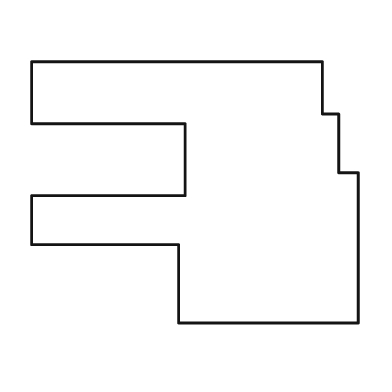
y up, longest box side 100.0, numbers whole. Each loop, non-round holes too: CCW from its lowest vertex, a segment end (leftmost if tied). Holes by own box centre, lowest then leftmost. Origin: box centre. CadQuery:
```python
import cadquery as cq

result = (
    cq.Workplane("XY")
    .moveTo(-5.0, -40.0)
    .lineTo(50.0, -40.0)
    .lineTo(50.0, 6.0)
    .lineTo(44.0, 6.0)
    .lineTo(44.0, 24.0)
    .lineTo(39.0, 24.0)
    .lineTo(39.0, 40.0)
    .lineTo(-50.0, 40.0)
    .lineTo(-50.0, 21.0)
    .lineTo(-3.0, 21.0)
    .lineTo(-3.0, -1.0)
    .lineTo(-50.0, -1.0)
    .lineTo(-50.0, -16.0)
    .lineTo(-5.0, -16.0)
    .close()
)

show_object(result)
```